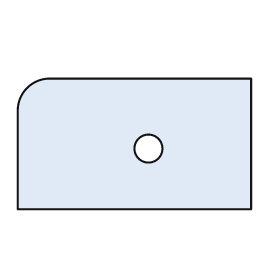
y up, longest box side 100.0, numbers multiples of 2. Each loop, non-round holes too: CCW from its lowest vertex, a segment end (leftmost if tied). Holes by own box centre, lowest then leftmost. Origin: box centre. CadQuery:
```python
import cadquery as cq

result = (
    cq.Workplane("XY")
    .moveTo(-50.0, -28.0)
    .lineTo(50.0, -28.0)
    .lineTo(50.0, 28.0)
    .lineTo(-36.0, 28.0)
    .threePointArc((-46.0, 24.0), (-50.0, 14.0))
    .close()
    .moveTo(6.0, -2.0)
    .circle(6.0)
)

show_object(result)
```